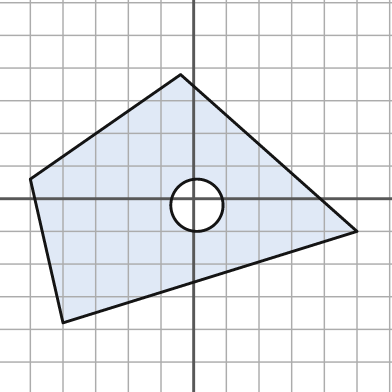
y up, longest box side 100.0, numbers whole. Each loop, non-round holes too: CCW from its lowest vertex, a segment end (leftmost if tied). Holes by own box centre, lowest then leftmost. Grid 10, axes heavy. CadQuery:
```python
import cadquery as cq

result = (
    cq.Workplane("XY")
    .moveTo(-40.0, -38.0)
    .lineTo(50.0, -10.0)
    .lineTo(-4.0, 38.0)
    .lineTo(-50.0, 6.0)
    .close()
    .moveTo(1.0, -2.0)
    .circle(8.0)
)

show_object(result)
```